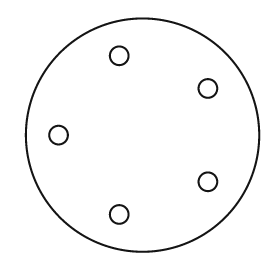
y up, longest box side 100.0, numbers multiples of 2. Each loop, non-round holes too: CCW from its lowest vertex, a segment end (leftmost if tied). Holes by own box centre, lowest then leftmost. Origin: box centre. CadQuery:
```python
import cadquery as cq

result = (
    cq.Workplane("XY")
    .moveTo(0.0, 0.0)
    .circle(50.0)
    .moveTo(-10.0, -34.0)
    .circle(4.0)
    .moveTo(28.0, -20.0)
    .circle(4.0)
    .moveTo(-36.0, 0.0)
    .circle(4.0)
    .moveTo(28.0, 20.0)
    .circle(4.0)
    .moveTo(-10.0, 34.0)
    .circle(4.0)
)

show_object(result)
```